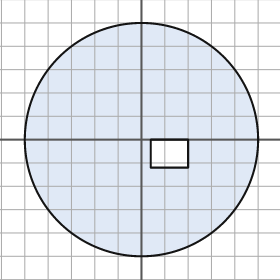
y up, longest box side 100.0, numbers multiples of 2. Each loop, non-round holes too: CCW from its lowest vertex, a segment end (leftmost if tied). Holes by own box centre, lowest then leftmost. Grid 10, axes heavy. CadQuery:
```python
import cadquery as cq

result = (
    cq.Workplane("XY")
    .moveTo(0.0, 0.0)
    .circle(50.0)
    .moveTo(4.0, -12.0)
    .lineTo(20.0, -12.0)
    .lineTo(20.0, 0.0)
    .lineTo(4.0, 0.0)
    .close()
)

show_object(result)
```